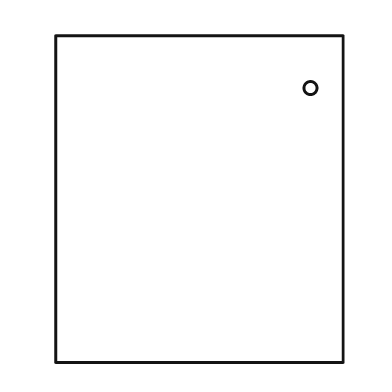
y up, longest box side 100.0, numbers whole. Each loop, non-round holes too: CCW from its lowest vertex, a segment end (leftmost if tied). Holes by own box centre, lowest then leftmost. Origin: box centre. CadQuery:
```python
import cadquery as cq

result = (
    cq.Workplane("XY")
    .moveTo(-44.0, -50.0)
    .lineTo(44.0, -50.0)
    .lineTo(44.0, 50.0)
    .lineTo(-44.0, 50.0)
    .close()
    .moveTo(34.0, 34.0)
    .circle(2.0)
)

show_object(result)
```